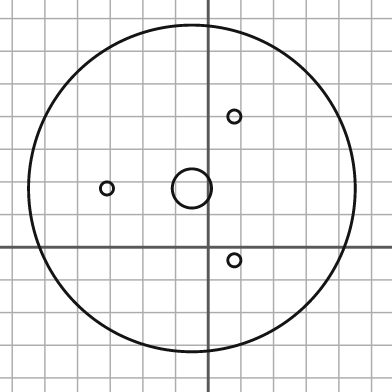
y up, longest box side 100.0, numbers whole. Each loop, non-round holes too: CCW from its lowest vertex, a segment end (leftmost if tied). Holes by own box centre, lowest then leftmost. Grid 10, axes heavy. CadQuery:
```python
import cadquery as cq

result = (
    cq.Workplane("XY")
    .moveTo(-5.0, 18.0)
    .circle(50.0)
    .moveTo(8.0, -4.0)
    .circle(2.0)
    .moveTo(-31.0, 18.0)
    .circle(2.0)
    .moveTo(-5.0, 18.0)
    .circle(6.0)
    .moveTo(8.0, 40.0)
    .circle(2.0)
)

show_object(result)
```